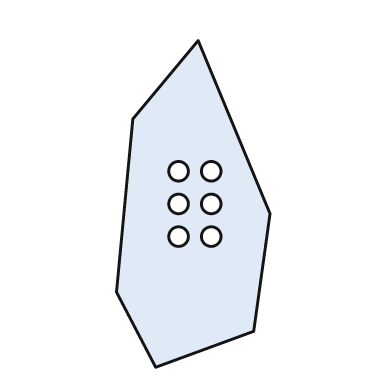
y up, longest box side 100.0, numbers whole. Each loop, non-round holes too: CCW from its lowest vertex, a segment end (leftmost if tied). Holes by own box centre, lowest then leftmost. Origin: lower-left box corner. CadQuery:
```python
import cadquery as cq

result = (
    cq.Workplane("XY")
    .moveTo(12.0, 0.0)
    .lineTo(42.0, 11.0)
    .lineTo(47.0, 47.0)
    .lineTo(25.0, 100.0)
    .lineTo(5.0, 76.0)
    .lineTo(0.0, 23.0)
    .close()
    .moveTo(19.0, 40.0)
    .circle(3.0)
    .moveTo(29.0, 40.0)
    .circle(3.0)
    .moveTo(19.0, 50.0)
    .circle(3.0)
    .moveTo(29.0, 50.0)
    .circle(3.0)
    .moveTo(19.0, 60.0)
    .circle(3.0)
    .moveTo(29.0, 60.0)
    .circle(3.0)
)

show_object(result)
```